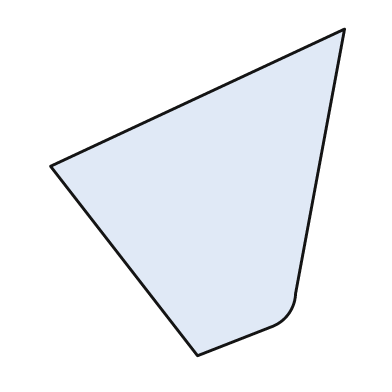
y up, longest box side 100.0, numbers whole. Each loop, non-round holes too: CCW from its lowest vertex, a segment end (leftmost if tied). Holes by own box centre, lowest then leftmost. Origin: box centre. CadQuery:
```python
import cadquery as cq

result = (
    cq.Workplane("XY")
    .moveTo(0.0, -50.0)
    .lineTo(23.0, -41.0)
    .threePointArc((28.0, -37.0), (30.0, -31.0))
    .lineTo(45.0, 50.0)
    .lineTo(-45.0, 8.0)
    .close()
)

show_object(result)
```